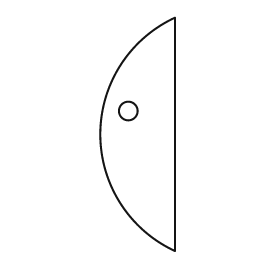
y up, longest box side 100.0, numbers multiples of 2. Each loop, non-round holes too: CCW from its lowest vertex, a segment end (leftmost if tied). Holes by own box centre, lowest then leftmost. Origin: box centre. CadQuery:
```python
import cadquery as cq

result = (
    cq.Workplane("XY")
    .moveTo(16.0, -50.0)
    .lineTo(16.0, 50.0)
    .threePointArc((-16.0, 0.0), (16.0, -50.0))
    .close()
    .moveTo(-4.0, 10.0)
    .circle(4.0)
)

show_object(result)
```